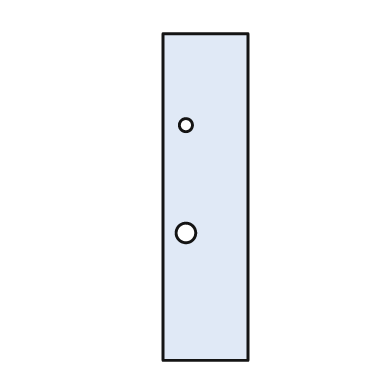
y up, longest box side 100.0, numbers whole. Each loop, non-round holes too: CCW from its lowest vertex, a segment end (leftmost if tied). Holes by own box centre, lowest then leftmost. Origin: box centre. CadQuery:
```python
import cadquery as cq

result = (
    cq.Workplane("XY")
    .moveTo(-13.0, -50.0)
    .lineTo(13.0, -50.0)
    .lineTo(13.0, 50.0)
    .lineTo(-13.0, 50.0)
    .close()
    .moveTo(-6.0, -11.0)
    .circle(3.0)
    .moveTo(-6.0, 22.0)
    .circle(2.0)
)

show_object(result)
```